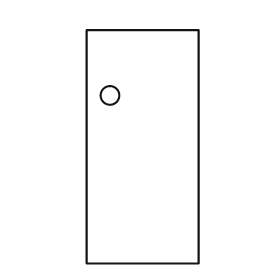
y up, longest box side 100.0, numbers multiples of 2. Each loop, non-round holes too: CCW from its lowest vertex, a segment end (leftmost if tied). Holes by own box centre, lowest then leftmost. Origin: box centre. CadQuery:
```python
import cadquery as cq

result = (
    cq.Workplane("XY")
    .moveTo(-24.0, -50.0)
    .lineTo(24.0, -50.0)
    .lineTo(24.0, 50.0)
    .lineTo(-24.0, 50.0)
    .close()
    .moveTo(-14.0, 22.0)
    .circle(4.0)
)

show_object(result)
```